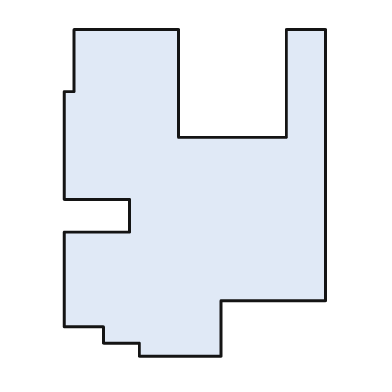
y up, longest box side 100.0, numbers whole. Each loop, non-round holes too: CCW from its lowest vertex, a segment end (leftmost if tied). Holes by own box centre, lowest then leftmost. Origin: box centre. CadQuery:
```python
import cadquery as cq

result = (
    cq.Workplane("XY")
    .moveTo(-17.0, -50.0)
    .lineTo(8.0, -50.0)
    .lineTo(8.0, -33.0)
    .lineTo(40.0, -33.0)
    .lineTo(40.0, 50.0)
    .lineTo(28.0, 50.0)
    .lineTo(28.0, 17.0)
    .lineTo(-5.0, 17.0)
    .lineTo(-5.0, 50.0)
    .lineTo(-37.0, 50.0)
    .lineTo(-37.0, 31.0)
    .lineTo(-40.0, 31.0)
    .lineTo(-40.0, -2.0)
    .lineTo(-20.0, -2.0)
    .lineTo(-20.0, -12.0)
    .lineTo(-40.0, -12.0)
    .lineTo(-40.0, -41.0)
    .lineTo(-28.0, -41.0)
    .lineTo(-28.0, -46.0)
    .lineTo(-17.0, -46.0)
    .close()
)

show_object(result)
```